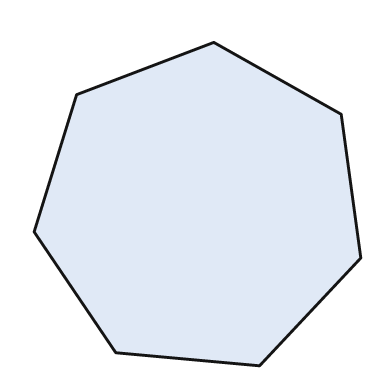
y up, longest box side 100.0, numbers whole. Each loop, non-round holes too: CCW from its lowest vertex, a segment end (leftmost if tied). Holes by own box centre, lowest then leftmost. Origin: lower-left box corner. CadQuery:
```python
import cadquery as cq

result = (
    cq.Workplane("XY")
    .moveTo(69.0, 0.0)
    .lineTo(100.0, 33.0)
    .lineTo(94.0, 77.0)
    .lineTo(55.0, 99.0)
    .lineTo(13.0, 83.0)
    .lineTo(0.0, 41.0)
    .lineTo(25.0, 4.0)
    .close()
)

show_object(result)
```